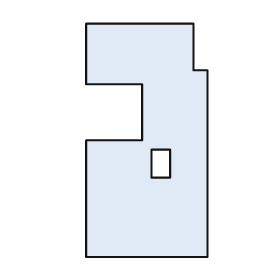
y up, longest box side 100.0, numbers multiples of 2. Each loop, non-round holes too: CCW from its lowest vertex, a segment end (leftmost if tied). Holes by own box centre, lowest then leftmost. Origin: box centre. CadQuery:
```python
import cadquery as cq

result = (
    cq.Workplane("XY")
    .moveTo(-26.0, -50.0)
    .lineTo(26.0, -50.0)
    .lineTo(26.0, 30.0)
    .lineTo(20.0, 30.0)
    .lineTo(20.0, 50.0)
    .lineTo(-26.0, 50.0)
    .lineTo(-26.0, 24.0)
    .lineTo(-2.0, 24.0)
    .lineTo(-2.0, 0.0)
    .lineTo(-26.0, 0.0)
    .close()
    .moveTo(2.0, -16.0)
    .lineTo(10.0, -16.0)
    .lineTo(10.0, -4.0)
    .lineTo(2.0, -4.0)
    .close()
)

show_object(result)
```